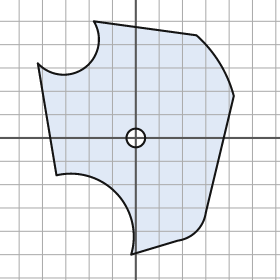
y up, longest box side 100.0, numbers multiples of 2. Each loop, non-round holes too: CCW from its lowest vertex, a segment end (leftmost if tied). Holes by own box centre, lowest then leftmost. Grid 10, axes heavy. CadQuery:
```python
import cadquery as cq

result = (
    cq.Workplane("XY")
    .moveTo(-2.0, -50.0)
    .lineTo(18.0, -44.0)
    .threePointArc((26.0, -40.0), (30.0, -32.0))
    .lineTo(42.0, 18.0)
    .threePointArc((36.0, 32.0), (26.0, 44.0))
    .lineTo(-18.0, 50.0)
    .threePointArc((-22.0, 30.0), (-42.0, 32.0))
    .lineTo(-34.0, -16.0)
    .threePointArc((-8.0, -24.0), (-2.0, -50.0))
    .close()
    .moveTo(0.0, 0.0)
    .circle(4.0)
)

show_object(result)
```